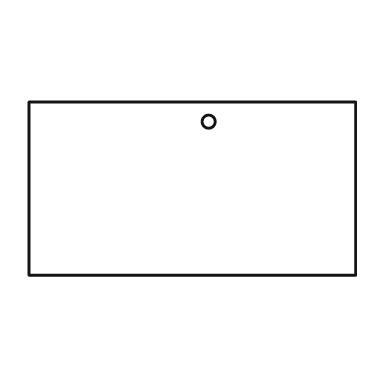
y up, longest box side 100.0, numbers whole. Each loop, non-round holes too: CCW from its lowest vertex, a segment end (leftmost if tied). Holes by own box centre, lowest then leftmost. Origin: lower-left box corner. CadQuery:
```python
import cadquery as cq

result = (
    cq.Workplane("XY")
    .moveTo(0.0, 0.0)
    .lineTo(100.0, 0.0)
    .lineTo(100.0, 53.0)
    .lineTo(0.0, 53.0)
    .close()
    .moveTo(55.0, 47.0)
    .circle(2.0)
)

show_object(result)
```